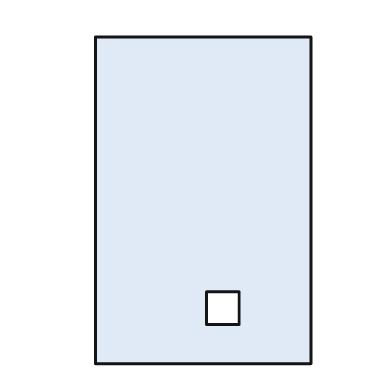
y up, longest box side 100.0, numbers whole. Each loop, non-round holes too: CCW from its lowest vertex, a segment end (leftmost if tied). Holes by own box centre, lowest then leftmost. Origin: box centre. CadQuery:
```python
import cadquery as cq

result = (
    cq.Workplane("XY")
    .moveTo(-33.0, -50.0)
    .lineTo(33.0, -50.0)
    .lineTo(33.0, 50.0)
    .lineTo(-33.0, 50.0)
    .close()
    .moveTo(1.0, -38.0)
    .lineTo(11.0, -38.0)
    .lineTo(11.0, -28.0)
    .lineTo(1.0, -28.0)
    .close()
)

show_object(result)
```